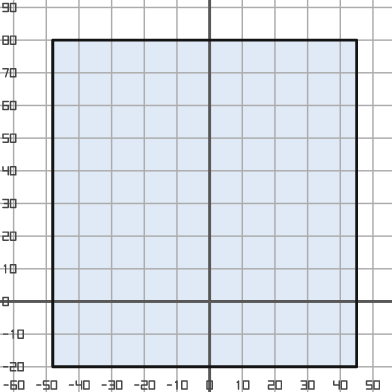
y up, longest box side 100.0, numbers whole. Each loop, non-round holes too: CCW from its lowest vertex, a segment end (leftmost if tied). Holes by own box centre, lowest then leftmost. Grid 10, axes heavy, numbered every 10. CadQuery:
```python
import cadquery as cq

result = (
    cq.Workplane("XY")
    .moveTo(-48.0, -20.0)
    .lineTo(45.0, -20.0)
    .lineTo(45.0, 80.0)
    .lineTo(-48.0, 80.0)
    .close()
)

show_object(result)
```